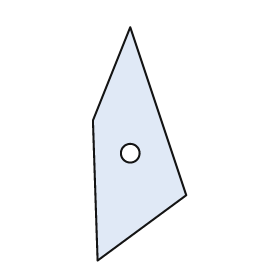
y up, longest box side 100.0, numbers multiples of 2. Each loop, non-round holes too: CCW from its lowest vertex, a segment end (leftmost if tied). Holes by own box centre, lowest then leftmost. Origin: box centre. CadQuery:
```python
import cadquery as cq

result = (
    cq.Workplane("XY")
    .moveTo(-18.0, -50.0)
    .lineTo(20.0, -22.0)
    .lineTo(-4.0, 50.0)
    .lineTo(-20.0, 10.0)
    .close()
    .moveTo(-4.0, -4.0)
    .circle(4.0)
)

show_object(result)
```